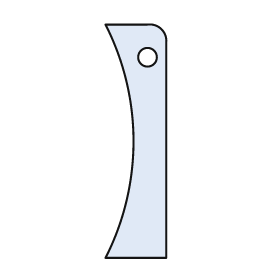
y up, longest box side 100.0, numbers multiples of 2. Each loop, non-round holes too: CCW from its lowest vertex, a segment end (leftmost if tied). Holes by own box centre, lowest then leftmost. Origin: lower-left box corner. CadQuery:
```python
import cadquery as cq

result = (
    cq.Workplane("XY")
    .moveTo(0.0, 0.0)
    .lineTo(26.0, 0.0)
    .lineTo(26.0, 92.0)
    .threePointArc((24.0, 98.0), (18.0, 100.0))
    .lineTo(0.0, 100.0)
    .threePointArc((12.0, 50.0), (0.0, 0.0))
    .close()
    .moveTo(18.0, 86.0)
    .circle(4.0)
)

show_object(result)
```